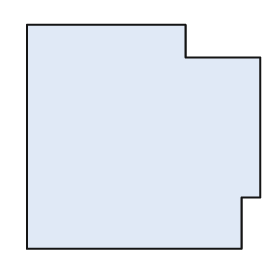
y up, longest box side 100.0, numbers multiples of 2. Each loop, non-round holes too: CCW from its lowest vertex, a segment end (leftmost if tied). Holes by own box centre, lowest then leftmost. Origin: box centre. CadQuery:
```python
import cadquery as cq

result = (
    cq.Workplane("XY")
    .moveTo(-50.0, -48.0)
    .lineTo(42.0, -48.0)
    .lineTo(42.0, -26.0)
    .lineTo(50.0, -26.0)
    .lineTo(50.0, 34.0)
    .lineTo(18.0, 34.0)
    .lineTo(18.0, 48.0)
    .lineTo(-50.0, 48.0)
    .close()
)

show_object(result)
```